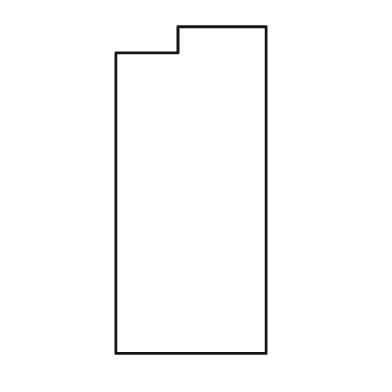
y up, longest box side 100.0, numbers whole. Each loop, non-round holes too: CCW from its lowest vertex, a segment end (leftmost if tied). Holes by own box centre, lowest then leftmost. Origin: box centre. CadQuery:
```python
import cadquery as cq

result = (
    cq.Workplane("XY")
    .moveTo(-23.0, -50.0)
    .lineTo(23.0, -50.0)
    .lineTo(23.0, 50.0)
    .lineTo(-4.0, 50.0)
    .lineTo(-4.0, 42.0)
    .lineTo(-23.0, 42.0)
    .close()
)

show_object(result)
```